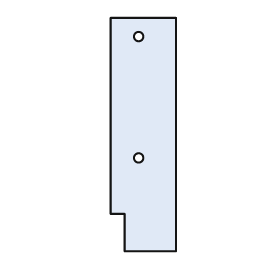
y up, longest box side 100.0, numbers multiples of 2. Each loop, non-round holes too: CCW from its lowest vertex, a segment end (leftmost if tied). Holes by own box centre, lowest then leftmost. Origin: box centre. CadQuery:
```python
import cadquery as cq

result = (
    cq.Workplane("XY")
    .moveTo(-8.0, -50.0)
    .lineTo(14.0, -50.0)
    .lineTo(14.0, 50.0)
    .lineTo(-14.0, 50.0)
    .lineTo(-14.0, -34.0)
    .lineTo(-8.0, -34.0)
    .close()
    .moveTo(-2.0, -10.0)
    .circle(2.0)
    .moveTo(-2.0, 42.0)
    .circle(2.0)
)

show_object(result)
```